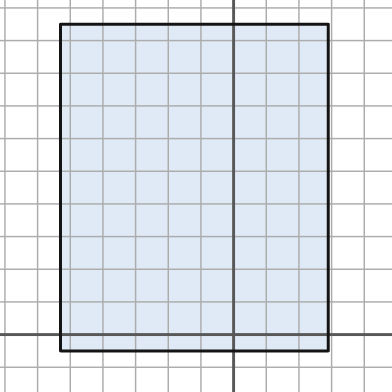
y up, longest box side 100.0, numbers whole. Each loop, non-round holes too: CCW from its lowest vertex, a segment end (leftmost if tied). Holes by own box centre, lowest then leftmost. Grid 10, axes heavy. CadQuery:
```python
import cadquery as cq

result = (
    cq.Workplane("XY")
    .moveTo(-53.0, -5.0)
    .lineTo(29.0, -5.0)
    .lineTo(29.0, 95.0)
    .lineTo(-53.0, 95.0)
    .close()
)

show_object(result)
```